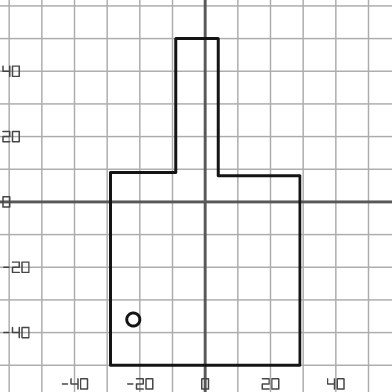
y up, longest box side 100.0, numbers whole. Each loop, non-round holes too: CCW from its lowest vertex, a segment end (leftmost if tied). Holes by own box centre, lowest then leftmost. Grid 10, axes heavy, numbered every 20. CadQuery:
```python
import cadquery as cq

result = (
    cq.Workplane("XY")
    .moveTo(-29.0, -50.0)
    .lineTo(29.0, -50.0)
    .lineTo(29.0, 8.0)
    .lineTo(4.0, 8.0)
    .lineTo(4.0, 50.0)
    .lineTo(-9.0, 50.0)
    .lineTo(-9.0, 9.0)
    .lineTo(-29.0, 9.0)
    .close()
    .moveTo(-22.0, -36.0)
    .circle(2.0)
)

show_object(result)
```